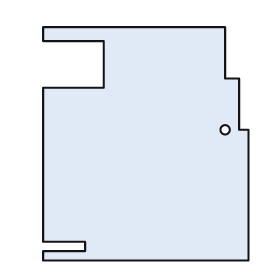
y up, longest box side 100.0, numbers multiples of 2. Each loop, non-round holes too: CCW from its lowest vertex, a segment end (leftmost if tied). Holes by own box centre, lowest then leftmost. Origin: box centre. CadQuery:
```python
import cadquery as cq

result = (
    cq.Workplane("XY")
    .moveTo(-44.0, -50.0)
    .lineTo(44.0, -50.0)
    .lineTo(44.0, 6.0)
    .lineTo(40.0, 6.0)
    .lineTo(40.0, 28.0)
    .lineTo(34.0, 28.0)
    .lineTo(34.0, 50.0)
    .lineTo(-44.0, 50.0)
    .lineTo(-44.0, 44.0)
    .lineTo(-18.0, 44.0)
    .lineTo(-18.0, 24.0)
    .lineTo(-44.0, 24.0)
    .lineTo(-44.0, -42.0)
    .lineTo(-26.0, -42.0)
    .lineTo(-26.0, -46.0)
    .lineTo(-44.0, -46.0)
    .close()
    .moveTo(34.0, 6.0)
    .circle(2.0)
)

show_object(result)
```